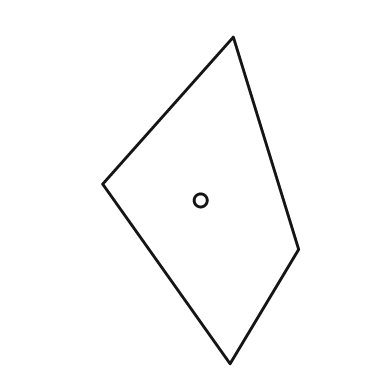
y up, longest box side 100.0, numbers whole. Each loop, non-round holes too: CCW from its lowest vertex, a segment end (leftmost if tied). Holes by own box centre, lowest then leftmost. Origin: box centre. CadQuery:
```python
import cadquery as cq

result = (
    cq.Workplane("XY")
    .moveTo(9.0, -50.0)
    .lineTo(30.0, -15.0)
    .lineTo(10.0, 50.0)
    .lineTo(-30.0, 5.0)
    .close()
    .moveTo(0.0, 0.0)
    .circle(2.0)
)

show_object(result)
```